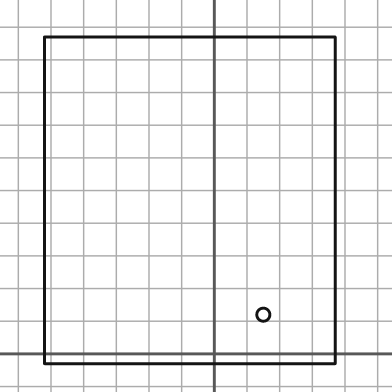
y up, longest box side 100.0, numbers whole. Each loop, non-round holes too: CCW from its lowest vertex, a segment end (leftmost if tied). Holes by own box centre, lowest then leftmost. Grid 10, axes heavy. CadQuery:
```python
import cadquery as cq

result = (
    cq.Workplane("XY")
    .moveTo(-52.0, -3.0)
    .lineTo(37.0, -3.0)
    .lineTo(37.0, 97.0)
    .lineTo(-52.0, 97.0)
    .close()
    .moveTo(15.0, 12.0)
    .circle(2.0)
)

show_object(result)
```